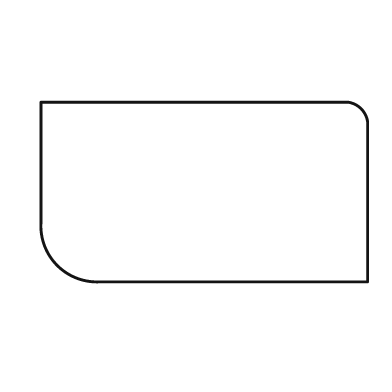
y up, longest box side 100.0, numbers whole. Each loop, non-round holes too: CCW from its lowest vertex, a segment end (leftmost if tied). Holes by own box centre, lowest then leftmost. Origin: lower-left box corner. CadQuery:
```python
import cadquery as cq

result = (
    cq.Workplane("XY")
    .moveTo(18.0, 0.0)
    .lineTo(100.0, 0.0)
    .lineTo(100.0, 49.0)
    .threePointArc((98.0, 53.0), (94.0, 55.0))
    .lineTo(0.0, 55.0)
    .lineTo(0.0, 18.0)
    .threePointArc((5.0, 5.0), (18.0, 0.0))
    .close()
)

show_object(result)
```